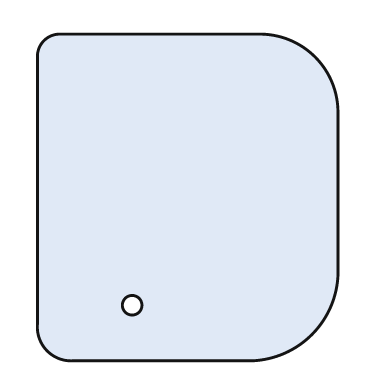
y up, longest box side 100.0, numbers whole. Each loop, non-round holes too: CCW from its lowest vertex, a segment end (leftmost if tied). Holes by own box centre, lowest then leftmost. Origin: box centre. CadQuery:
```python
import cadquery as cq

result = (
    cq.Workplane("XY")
    .moveTo(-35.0, -50.0)
    .lineTo(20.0, -50.0)
    .threePointArc((38.0, -42.0), (46.0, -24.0))
    .lineTo(46.0, 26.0)
    .threePointArc((39.0, 43.0), (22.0, 50.0))
    .lineTo(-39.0, 50.0)
    .threePointArc((-44.0, 48.0), (-46.0, 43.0))
    .lineTo(-46.0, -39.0)
    .threePointArc((-43.0, -47.0), (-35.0, -50.0))
    .close()
    .moveTo(-17.0, -33.0)
    .circle(3.0)
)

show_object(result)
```